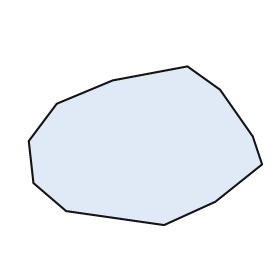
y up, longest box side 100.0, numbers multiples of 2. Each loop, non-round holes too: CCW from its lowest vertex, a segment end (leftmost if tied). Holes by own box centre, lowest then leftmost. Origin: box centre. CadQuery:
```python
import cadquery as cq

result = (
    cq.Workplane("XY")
    .moveTo(8.0, -34.0)
    .lineTo(30.0, -24.0)
    .lineTo(50.0, -8.0)
    .lineTo(46.0, 4.0)
    .lineTo(32.0, 24.0)
    .lineTo(18.0, 34.0)
    .lineTo(-14.0, 28.0)
    .lineTo(-38.0, 18.0)
    .lineTo(-50.0, 2.0)
    .lineTo(-48.0, -16.0)
    .lineTo(-34.0, -28.0)
    .close()
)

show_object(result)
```